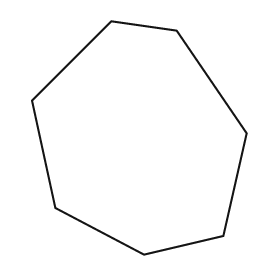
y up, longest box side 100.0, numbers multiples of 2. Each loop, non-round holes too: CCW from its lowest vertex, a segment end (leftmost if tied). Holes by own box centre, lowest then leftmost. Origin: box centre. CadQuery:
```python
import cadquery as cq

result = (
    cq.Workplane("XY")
    .moveTo(2.0, -50.0)
    .lineTo(36.0, -42.0)
    .lineTo(46.0, 2.0)
    .lineTo(16.0, 46.0)
    .lineTo(-12.0, 50.0)
    .lineTo(-46.0, 16.0)
    .lineTo(-36.0, -30.0)
    .close()
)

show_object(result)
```